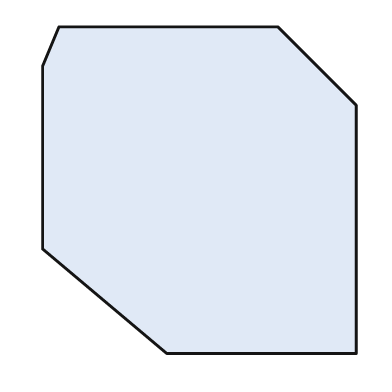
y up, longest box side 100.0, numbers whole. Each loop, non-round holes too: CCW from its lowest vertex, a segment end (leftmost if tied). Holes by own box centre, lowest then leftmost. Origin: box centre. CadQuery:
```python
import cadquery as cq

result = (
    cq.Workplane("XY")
    .moveTo(-10.0, -50.0)
    .lineTo(48.0, -50.0)
    .lineTo(48.0, 26.0)
    .lineTo(24.0, 50.0)
    .lineTo(-43.0, 50.0)
    .lineTo(-48.0, 38.0)
    .lineTo(-48.0, -18.0)
    .close()
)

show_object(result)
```